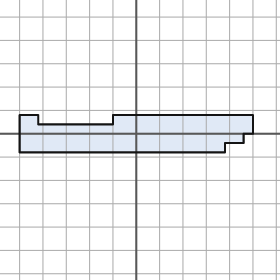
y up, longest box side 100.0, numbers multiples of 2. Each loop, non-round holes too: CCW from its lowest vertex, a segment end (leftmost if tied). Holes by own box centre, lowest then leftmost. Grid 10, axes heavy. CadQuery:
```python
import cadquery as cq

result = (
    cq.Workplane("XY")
    .moveTo(-50.0, -8.0)
    .lineTo(38.0, -8.0)
    .lineTo(38.0, -4.0)
    .lineTo(46.0, -4.0)
    .lineTo(46.0, 0.0)
    .lineTo(50.0, 0.0)
    .lineTo(50.0, 8.0)
    .lineTo(-10.0, 8.0)
    .lineTo(-10.0, 4.0)
    .lineTo(-42.0, 4.0)
    .lineTo(-42.0, 8.0)
    .lineTo(-50.0, 8.0)
    .close()
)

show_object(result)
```